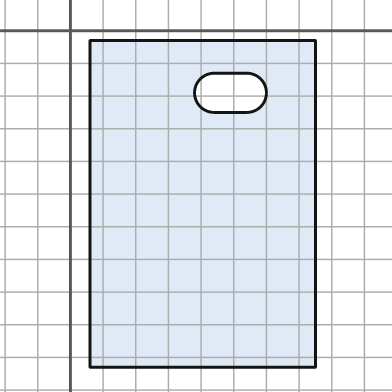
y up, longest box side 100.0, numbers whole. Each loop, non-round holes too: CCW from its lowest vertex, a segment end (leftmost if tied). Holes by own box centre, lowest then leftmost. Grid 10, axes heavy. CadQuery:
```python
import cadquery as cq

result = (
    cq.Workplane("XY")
    .moveTo(6.0, -103.0)
    .lineTo(75.0, -103.0)
    .lineTo(75.0, -3.0)
    .lineTo(6.0, -3.0)
    .close()
    .moveTo(44.0, -25.0)
    .lineTo(54.0, -25.0)
    .threePointArc((60.0, -19.0), (54.0, -13.0))
    .lineTo(44.0, -13.0)
    .threePointArc((38.0, -19.0), (44.0, -25.0))
    .close()
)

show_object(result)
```